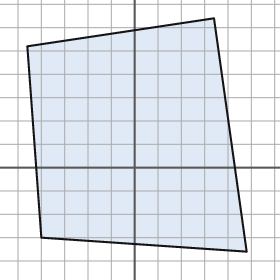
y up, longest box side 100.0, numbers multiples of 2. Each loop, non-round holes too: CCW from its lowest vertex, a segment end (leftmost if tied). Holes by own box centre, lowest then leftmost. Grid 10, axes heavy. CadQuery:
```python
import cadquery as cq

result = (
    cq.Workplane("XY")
    .moveTo(48.0, -36.0)
    .lineTo(34.0, 64.0)
    .lineTo(-46.0, 52.0)
    .lineTo(-40.0, -30.0)
    .close()
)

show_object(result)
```